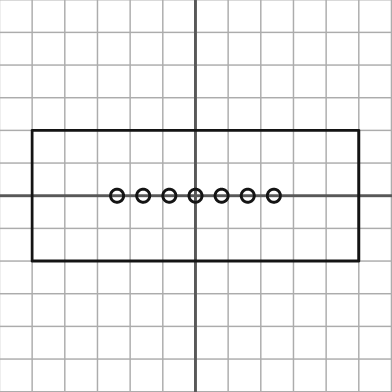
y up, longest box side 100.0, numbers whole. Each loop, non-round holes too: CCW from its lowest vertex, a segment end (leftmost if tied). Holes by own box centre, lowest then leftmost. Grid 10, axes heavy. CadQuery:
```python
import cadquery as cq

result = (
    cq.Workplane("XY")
    .moveTo(-50.0, -20.0)
    .lineTo(50.0, -20.0)
    .lineTo(50.0, 20.0)
    .lineTo(-50.0, 20.0)
    .close()
    .moveTo(-24.0, 0.0)
    .circle(2.0)
    .moveTo(-16.0, 0.0)
    .circle(2.0)
    .moveTo(-8.0, 0.0)
    .circle(2.0)
    .moveTo(0.0, 0.0)
    .circle(2.0)
    .moveTo(8.0, 0.0)
    .circle(2.0)
    .moveTo(16.0, 0.0)
    .circle(2.0)
    .moveTo(24.0, 0.0)
    .circle(2.0)
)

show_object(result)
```